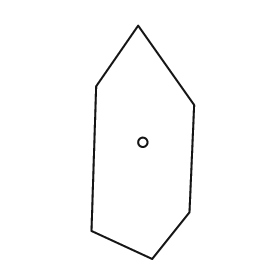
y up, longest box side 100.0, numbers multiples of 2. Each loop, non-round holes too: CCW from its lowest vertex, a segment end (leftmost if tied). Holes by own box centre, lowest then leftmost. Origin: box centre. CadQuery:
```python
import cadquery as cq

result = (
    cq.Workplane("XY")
    .moveTo(4.0, -50.0)
    .lineTo(20.0, -30.0)
    .lineTo(22.0, 16.0)
    .lineTo(-2.0, 50.0)
    .lineTo(-20.0, 24.0)
    .lineTo(-22.0, -38.0)
    .close()
    .moveTo(0.0, 0.0)
    .circle(2.0)
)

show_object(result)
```